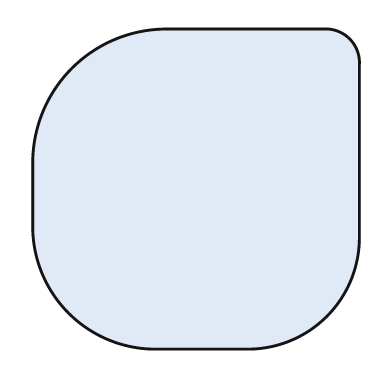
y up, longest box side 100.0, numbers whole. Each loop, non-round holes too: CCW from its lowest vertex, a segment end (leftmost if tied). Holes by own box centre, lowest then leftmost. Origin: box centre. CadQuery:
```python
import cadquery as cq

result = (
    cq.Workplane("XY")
    .moveTo(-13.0, -49.0)
    .lineTo(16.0, -49.0)
    .threePointArc((40.0, -39.0), (50.0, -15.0))
    .lineTo(50.0, 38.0)
    .threePointArc((47.0, 46.0), (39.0, 49.0))
    .lineTo(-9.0, 49.0)
    .threePointArc((-38.0, 37.0), (-50.0, 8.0))
    .lineTo(-50.0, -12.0)
    .threePointArc((-39.0, -38.0), (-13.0, -49.0))
    .close()
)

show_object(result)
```